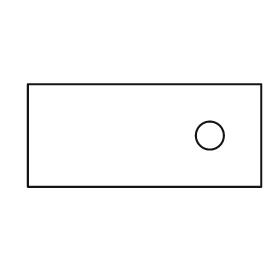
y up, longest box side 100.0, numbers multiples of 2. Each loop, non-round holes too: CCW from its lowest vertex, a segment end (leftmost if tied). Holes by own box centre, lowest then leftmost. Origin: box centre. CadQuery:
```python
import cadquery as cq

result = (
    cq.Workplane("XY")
    .moveTo(-50.0, -22.0)
    .lineTo(50.0, -22.0)
    .lineTo(50.0, 22.0)
    .lineTo(-50.0, 22.0)
    .close()
    .moveTo(28.0, 0.0)
    .circle(6.0)
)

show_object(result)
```